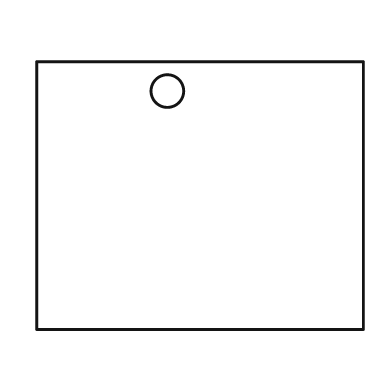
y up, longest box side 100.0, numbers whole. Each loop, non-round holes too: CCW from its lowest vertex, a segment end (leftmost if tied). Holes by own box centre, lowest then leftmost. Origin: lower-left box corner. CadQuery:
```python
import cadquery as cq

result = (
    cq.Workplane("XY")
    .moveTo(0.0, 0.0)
    .lineTo(100.0, 0.0)
    .lineTo(100.0, 82.0)
    .lineTo(0.0, 82.0)
    .close()
    .moveTo(40.0, 73.0)
    .circle(5.0)
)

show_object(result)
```